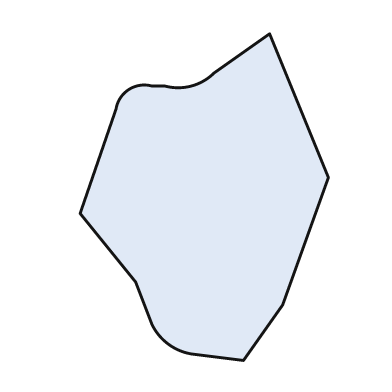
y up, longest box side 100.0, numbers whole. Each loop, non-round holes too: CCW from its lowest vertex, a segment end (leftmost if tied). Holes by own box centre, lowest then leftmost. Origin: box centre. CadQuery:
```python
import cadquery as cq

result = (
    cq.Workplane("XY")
    .moveTo(12.0, -50.0)
    .lineTo(24.0, -33.0)
    .lineTo(38.0, 6.0)
    .lineTo(20.0, 50.0)
    .lineTo(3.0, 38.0)
    .threePointArc((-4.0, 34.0), (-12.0, 34.0))
    .lineTo(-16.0, 34.0)
    .threePointArc((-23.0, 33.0), (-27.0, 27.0))
    .lineTo(-38.0, -5.0)
    .lineTo(-21.0, -26.0)
    .lineTo(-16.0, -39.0)
    .threePointArc((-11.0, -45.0), (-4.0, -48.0))
    .close()
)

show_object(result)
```